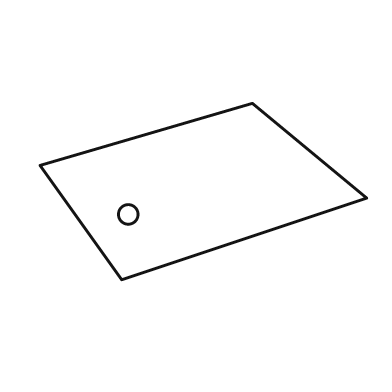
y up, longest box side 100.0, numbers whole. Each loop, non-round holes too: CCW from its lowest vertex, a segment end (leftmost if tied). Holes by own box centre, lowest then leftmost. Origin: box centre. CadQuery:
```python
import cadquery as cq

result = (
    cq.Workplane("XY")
    .moveTo(-25.0, -27.0)
    .lineTo(50.0, -2.0)
    .lineTo(15.0, 27.0)
    .lineTo(-50.0, 8.0)
    .close()
    .moveTo(-23.0, -7.0)
    .circle(3.0)
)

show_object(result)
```